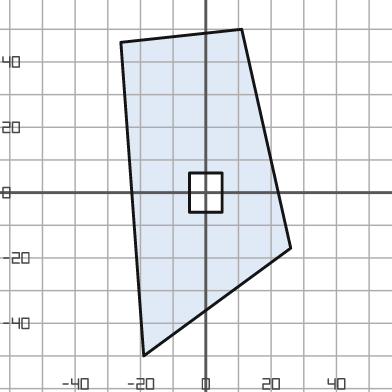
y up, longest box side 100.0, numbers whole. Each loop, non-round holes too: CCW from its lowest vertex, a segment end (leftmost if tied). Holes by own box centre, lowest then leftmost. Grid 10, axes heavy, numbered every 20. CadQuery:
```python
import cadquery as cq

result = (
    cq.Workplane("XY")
    .moveTo(-19.0, -50.0)
    .lineTo(26.0, -17.0)
    .lineTo(11.0, 50.0)
    .lineTo(-26.0, 46.0)
    .close()
    .moveTo(-5.0, -6.0)
    .lineTo(5.0, -6.0)
    .lineTo(5.0, 6.0)
    .lineTo(-5.0, 6.0)
    .close()
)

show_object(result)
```